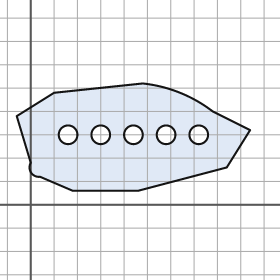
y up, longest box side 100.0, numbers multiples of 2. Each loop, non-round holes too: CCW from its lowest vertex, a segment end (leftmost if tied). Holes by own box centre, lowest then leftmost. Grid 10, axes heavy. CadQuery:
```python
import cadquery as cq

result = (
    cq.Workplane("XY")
    .moveTo(18.0, 6.0)
    .lineTo(46.0, 6.0)
    .lineTo(84.0, 16.0)
    .lineTo(94.0, 32.0)
    .lineTo(78.0, 40.0)
    .threePointArc((64.0, 48.0), (48.0, 52.0))
    .lineTo(10.0, 48.0)
    .lineTo(-6.0, 38.0)
    .lineTo(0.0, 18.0)
    .threePointArc((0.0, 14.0), (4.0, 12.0))
    .close()
    .moveTo(16.0, 30.0)
    .circle(4.0)
    .moveTo(30.0, 30.0)
    .circle(4.0)
    .moveTo(44.0, 30.0)
    .circle(4.0)
    .moveTo(58.0, 30.0)
    .circle(4.0)
    .moveTo(72.0, 30.0)
    .circle(4.0)
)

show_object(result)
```